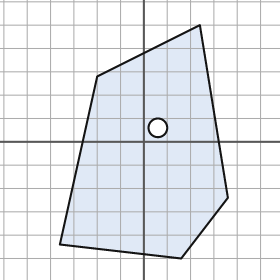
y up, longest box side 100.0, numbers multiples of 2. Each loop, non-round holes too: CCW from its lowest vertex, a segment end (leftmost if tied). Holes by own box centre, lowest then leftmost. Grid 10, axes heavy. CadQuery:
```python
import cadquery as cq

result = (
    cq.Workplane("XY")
    .moveTo(16.0, -50.0)
    .lineTo(36.0, -24.0)
    .lineTo(24.0, 50.0)
    .lineTo(-20.0, 28.0)
    .lineTo(-36.0, -44.0)
    .close()
    .moveTo(6.0, 6.0)
    .circle(4.0)
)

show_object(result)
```